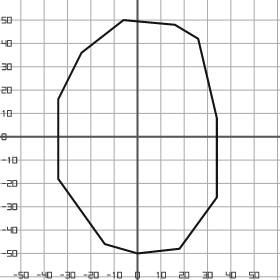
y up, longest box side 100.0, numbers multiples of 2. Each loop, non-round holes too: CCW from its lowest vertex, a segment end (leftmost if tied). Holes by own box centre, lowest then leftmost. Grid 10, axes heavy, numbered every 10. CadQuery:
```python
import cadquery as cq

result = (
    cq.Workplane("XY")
    .moveTo(0.0, -50.0)
    .lineTo(18.0, -48.0)
    .lineTo(34.0, -26.0)
    .lineTo(34.0, 8.0)
    .lineTo(26.0, 42.0)
    .lineTo(16.0, 48.0)
    .lineTo(-6.0, 50.0)
    .lineTo(-24.0, 36.0)
    .lineTo(-34.0, 16.0)
    .lineTo(-34.0, -18.0)
    .lineTo(-14.0, -46.0)
    .close()
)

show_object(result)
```